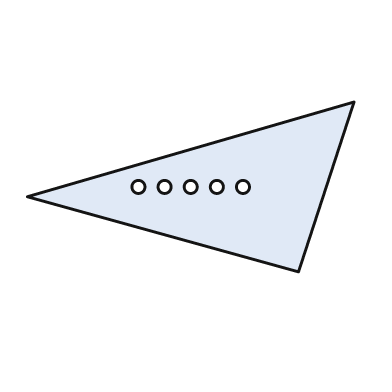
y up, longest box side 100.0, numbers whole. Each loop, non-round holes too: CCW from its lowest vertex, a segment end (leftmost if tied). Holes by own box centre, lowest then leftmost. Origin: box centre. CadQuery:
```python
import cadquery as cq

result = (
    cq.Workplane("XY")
    .moveTo(33.0, -26.0)
    .lineTo(50.0, 26.0)
    .lineTo(-50.0, -3.0)
    .close()
    .moveTo(-16.0, 0.0)
    .circle(2.0)
    .moveTo(-8.0, 0.0)
    .circle(2.0)
    .moveTo(0.0, 0.0)
    .circle(2.0)
    .moveTo(8.0, 0.0)
    .circle(2.0)
    .moveTo(16.0, 0.0)
    .circle(2.0)
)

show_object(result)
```